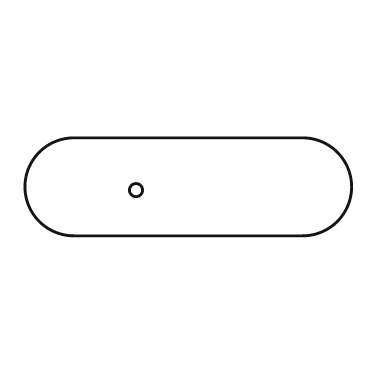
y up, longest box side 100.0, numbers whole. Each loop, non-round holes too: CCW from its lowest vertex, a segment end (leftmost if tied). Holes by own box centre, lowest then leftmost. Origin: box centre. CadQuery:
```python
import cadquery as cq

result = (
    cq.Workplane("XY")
    .moveTo(-35.0, -15.0)
    .lineTo(35.0, -15.0)
    .threePointArc((50.0, 0.0), (35.0, 15.0))
    .lineTo(-35.0, 15.0)
    .threePointArc((-50.0, 0.0), (-35.0, -15.0))
    .close()
    .moveTo(-16.0, -1.0)
    .circle(2.0)
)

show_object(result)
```